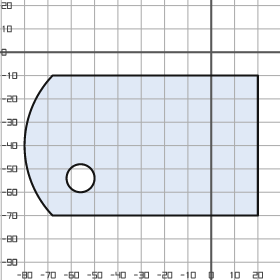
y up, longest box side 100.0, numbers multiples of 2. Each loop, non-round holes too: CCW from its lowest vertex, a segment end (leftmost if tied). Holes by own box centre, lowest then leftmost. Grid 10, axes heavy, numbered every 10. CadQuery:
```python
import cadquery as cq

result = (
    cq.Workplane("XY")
    .moveTo(-68.0, -70.0)
    .lineTo(20.0, -70.0)
    .lineTo(20.0, -10.0)
    .lineTo(-68.0, -10.0)
    .threePointArc((-80.0, -40.0), (-68.0, -70.0))
    .close()
    .moveTo(-56.0, -54.0)
    .circle(6.0)
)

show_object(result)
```